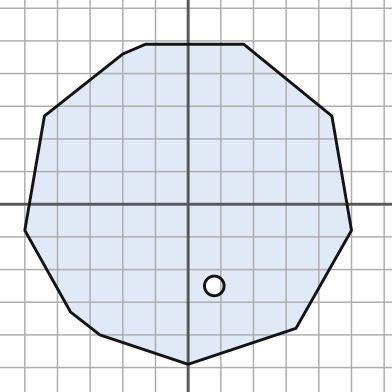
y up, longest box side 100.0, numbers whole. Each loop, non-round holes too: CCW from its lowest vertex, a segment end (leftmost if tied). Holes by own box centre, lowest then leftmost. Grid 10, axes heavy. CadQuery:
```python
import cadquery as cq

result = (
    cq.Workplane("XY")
    .moveTo(0.0, -49.0)
    .lineTo(33.0, -38.0)
    .lineTo(50.0, -8.0)
    .lineTo(44.0, 27.0)
    .lineTo(17.0, 49.0)
    .lineTo(-13.0, 49.0)
    .lineTo(-20.0, 46.0)
    .lineTo(-44.0, 27.0)
    .lineTo(-50.0, -8.0)
    .lineTo(-36.0, -33.0)
    .lineTo(-27.0, -40.0)
    .close()
    .moveTo(8.0, -25.0)
    .circle(3.0)
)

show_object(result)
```